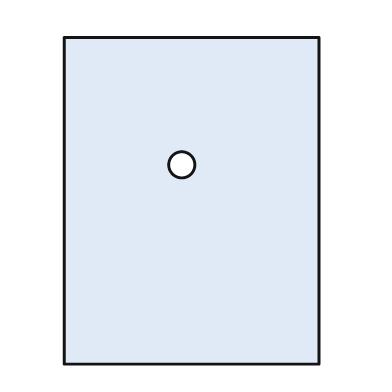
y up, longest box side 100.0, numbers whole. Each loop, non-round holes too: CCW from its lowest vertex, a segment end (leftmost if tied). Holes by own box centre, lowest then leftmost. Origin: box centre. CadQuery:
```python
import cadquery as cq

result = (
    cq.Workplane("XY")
    .moveTo(-39.0, -50.0)
    .lineTo(39.0, -50.0)
    .lineTo(39.0, 50.0)
    .lineTo(-39.0, 50.0)
    .close()
    .moveTo(-3.0, 11.0)
    .circle(4.0)
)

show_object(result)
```